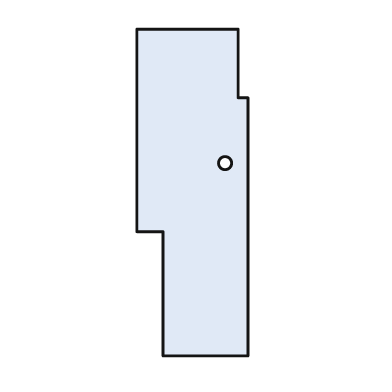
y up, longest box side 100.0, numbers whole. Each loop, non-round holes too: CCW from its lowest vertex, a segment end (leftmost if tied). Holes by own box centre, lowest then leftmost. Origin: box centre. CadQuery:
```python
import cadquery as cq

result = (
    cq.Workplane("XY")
    .moveTo(-9.0, -50.0)
    .lineTo(17.0, -50.0)
    .lineTo(17.0, 29.0)
    .lineTo(14.0, 29.0)
    .lineTo(14.0, 50.0)
    .lineTo(-17.0, 50.0)
    .lineTo(-17.0, -12.0)
    .lineTo(-9.0, -12.0)
    .close()
    .moveTo(10.0, 9.0)
    .circle(2.0)
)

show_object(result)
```